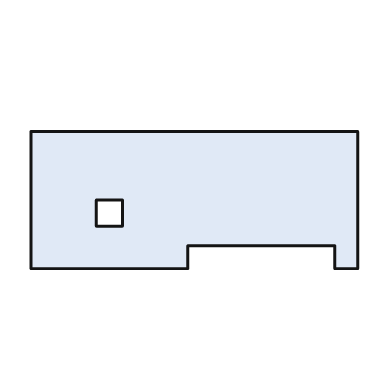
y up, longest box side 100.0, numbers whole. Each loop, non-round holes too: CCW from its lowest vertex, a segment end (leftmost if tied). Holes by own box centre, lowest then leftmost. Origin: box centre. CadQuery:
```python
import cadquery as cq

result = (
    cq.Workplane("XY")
    .moveTo(-50.0, -21.0)
    .lineTo(-2.0, -21.0)
    .lineTo(-2.0, -14.0)
    .lineTo(43.0, -14.0)
    .lineTo(43.0, -21.0)
    .lineTo(50.0, -21.0)
    .lineTo(50.0, 21.0)
    .lineTo(-50.0, 21.0)
    .close()
    .moveTo(-30.0, -8.0)
    .lineTo(-22.0, -8.0)
    .lineTo(-22.0, 0.0)
    .lineTo(-30.0, 0.0)
    .close()
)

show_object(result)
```